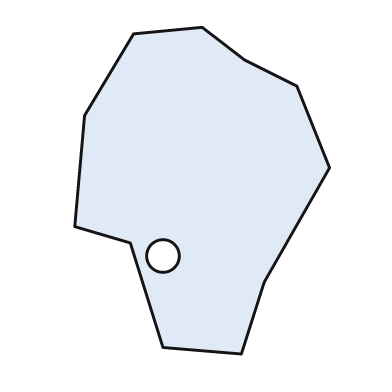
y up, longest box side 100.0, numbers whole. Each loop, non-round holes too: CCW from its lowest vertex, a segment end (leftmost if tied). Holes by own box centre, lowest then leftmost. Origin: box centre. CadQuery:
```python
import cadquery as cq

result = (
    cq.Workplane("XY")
    .moveTo(12.0, -50.0)
    .lineTo(19.0, -28.0)
    .lineTo(39.0, 7.0)
    .lineTo(29.0, 32.0)
    .lineTo(13.0, 40.0)
    .lineTo(0.0, 50.0)
    .lineTo(-21.0, 48.0)
    .lineTo(-36.0, 23.0)
    .lineTo(-39.0, -11.0)
    .lineTo(-22.0, -16.0)
    .lineTo(-12.0, -48.0)
    .close()
    .moveTo(-12.0, -20.0)
    .circle(5.0)
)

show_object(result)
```